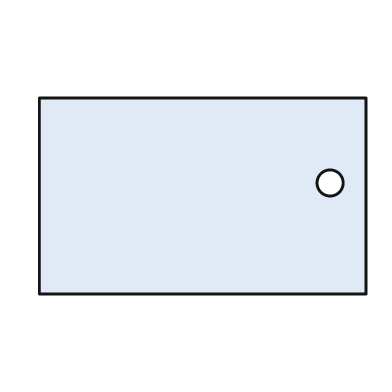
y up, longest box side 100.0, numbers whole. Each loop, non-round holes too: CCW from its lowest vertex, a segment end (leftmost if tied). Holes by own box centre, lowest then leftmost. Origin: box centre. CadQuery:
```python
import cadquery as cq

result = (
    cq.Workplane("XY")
    .moveTo(-50.0, -30.0)
    .lineTo(50.0, -30.0)
    .lineTo(50.0, 30.0)
    .lineTo(-50.0, 30.0)
    .close()
    .moveTo(39.0, 4.0)
    .circle(4.0)
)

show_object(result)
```